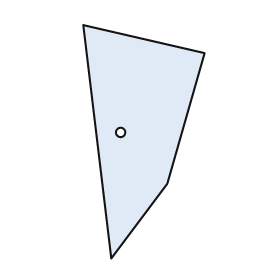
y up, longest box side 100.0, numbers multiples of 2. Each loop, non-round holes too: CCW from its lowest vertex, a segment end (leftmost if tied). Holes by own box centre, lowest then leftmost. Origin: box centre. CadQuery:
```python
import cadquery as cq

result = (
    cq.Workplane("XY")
    .moveTo(-14.0, -50.0)
    .lineTo(10.0, -18.0)
    .lineTo(26.0, 38.0)
    .lineTo(-26.0, 50.0)
    .close()
    .moveTo(-10.0, 4.0)
    .circle(2.0)
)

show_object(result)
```